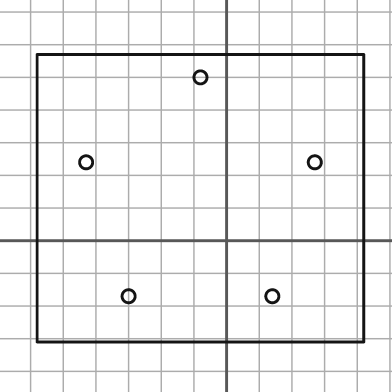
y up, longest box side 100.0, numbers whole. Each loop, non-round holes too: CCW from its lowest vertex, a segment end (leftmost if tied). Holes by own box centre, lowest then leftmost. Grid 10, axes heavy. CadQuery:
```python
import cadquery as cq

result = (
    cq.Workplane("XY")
    .moveTo(-58.0, -31.0)
    .lineTo(42.0, -31.0)
    .lineTo(42.0, 57.0)
    .lineTo(-58.0, 57.0)
    .close()
    .moveTo(-30.0, -17.0)
    .circle(2.0)
    .moveTo(14.0, -17.0)
    .circle(2.0)
    .moveTo(-43.0, 24.0)
    .circle(2.0)
    .moveTo(27.0, 24.0)
    .circle(2.0)
    .moveTo(-8.0, 50.0)
    .circle(2.0)
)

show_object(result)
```